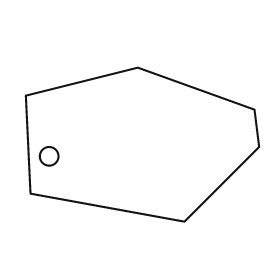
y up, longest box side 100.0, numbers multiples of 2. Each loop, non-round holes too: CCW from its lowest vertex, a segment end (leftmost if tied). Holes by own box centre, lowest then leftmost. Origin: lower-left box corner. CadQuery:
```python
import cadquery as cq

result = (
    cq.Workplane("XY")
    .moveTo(68.0, 0.0)
    .lineTo(100.0, 32.0)
    .lineTo(98.0, 48.0)
    .lineTo(48.0, 66.0)
    .lineTo(0.0, 54.0)
    .lineTo(2.0, 12.0)
    .close()
    .moveTo(10.0, 28.0)
    .circle(4.0)
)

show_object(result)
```